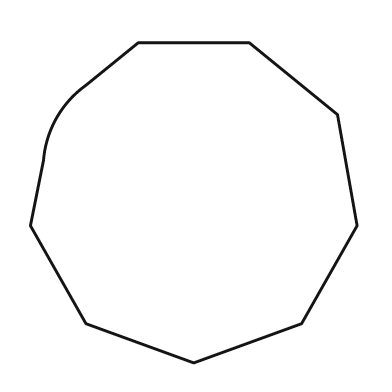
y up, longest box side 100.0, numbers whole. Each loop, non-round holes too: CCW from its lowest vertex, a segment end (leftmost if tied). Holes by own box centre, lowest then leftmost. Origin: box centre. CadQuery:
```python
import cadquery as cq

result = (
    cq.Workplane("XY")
    .moveTo(0.0, -49.0)
    .lineTo(33.0, -37.0)
    .lineTo(50.0, -7.0)
    .lineTo(44.0, 27.0)
    .lineTo(17.0, 49.0)
    .lineTo(-17.0, 49.0)
    .lineTo(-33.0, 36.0)
    .threePointArc((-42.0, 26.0), (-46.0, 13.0))
    .lineTo(-50.0, -7.0)
    .lineTo(-33.0, -37.0)
    .close()
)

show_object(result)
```